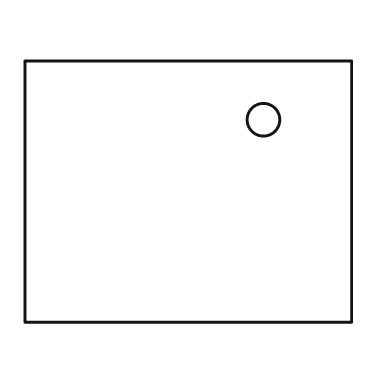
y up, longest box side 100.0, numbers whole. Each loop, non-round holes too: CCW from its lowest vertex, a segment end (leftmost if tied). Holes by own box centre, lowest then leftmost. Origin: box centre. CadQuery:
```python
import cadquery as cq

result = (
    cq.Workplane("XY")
    .moveTo(-50.0, -40.0)
    .lineTo(50.0, -40.0)
    .lineTo(50.0, 40.0)
    .lineTo(-50.0, 40.0)
    .close()
    .moveTo(23.0, 22.0)
    .circle(5.0)
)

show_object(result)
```